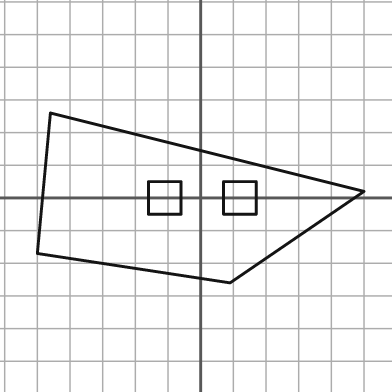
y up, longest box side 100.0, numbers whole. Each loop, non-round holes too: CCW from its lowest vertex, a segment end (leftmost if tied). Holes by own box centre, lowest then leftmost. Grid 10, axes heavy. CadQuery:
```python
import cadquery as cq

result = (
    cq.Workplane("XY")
    .moveTo(9.0, -26.0)
    .lineTo(50.0, 2.0)
    .lineTo(-46.0, 26.0)
    .lineTo(-50.0, -17.0)
    .close()
    .moveTo(-16.0, -5.0)
    .lineTo(-6.0, -5.0)
    .lineTo(-6.0, 5.0)
    .lineTo(-16.0, 5.0)
    .close()
    .moveTo(7.0, -5.0)
    .lineTo(17.0, -5.0)
    .lineTo(17.0, 5.0)
    .lineTo(7.0, 5.0)
    .close()
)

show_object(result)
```